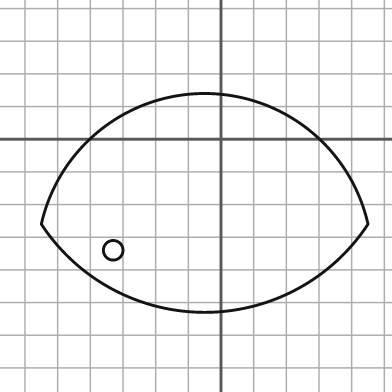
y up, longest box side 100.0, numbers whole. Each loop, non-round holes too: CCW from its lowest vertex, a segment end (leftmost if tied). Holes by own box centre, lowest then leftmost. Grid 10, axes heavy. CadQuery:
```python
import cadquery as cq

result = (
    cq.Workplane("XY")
    .moveTo(-55.0, -26.0)
    .threePointArc((-5.0, -53.0), (45.0, -26.0))
    .threePointArc((-5.0, 14.0), (-55.0, -26.0))
    .close()
    .moveTo(-33.0, -34.0)
    .circle(3.0)
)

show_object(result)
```